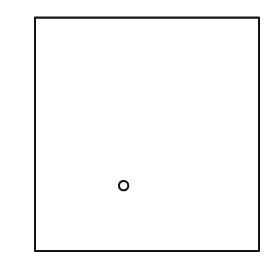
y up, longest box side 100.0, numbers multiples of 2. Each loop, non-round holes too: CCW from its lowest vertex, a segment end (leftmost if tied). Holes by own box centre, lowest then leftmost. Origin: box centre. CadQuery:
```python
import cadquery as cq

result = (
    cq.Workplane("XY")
    .moveTo(-48.0, -50.0)
    .lineTo(48.0, -50.0)
    .lineTo(48.0, 50.0)
    .lineTo(-48.0, 50.0)
    .close()
    .moveTo(-10.0, -22.0)
    .circle(2.0)
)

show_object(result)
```